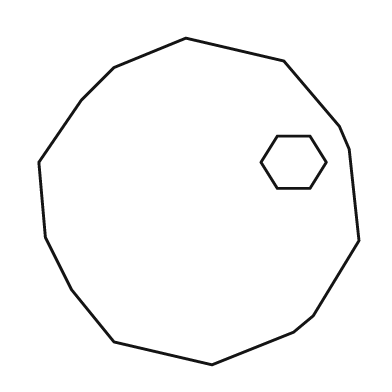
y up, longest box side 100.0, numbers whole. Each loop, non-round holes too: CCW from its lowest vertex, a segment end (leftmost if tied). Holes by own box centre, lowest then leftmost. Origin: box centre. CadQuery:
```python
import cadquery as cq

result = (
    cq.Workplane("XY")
    .moveTo(4.0, -50.0)
    .lineTo(29.0, -40.0)
    .lineTo(35.0, -35.0)
    .lineTo(49.0, -12.0)
    .lineTo(46.0, 16.0)
    .lineTo(43.0, 23.0)
    .lineTo(26.0, 43.0)
    .lineTo(-4.0, 50.0)
    .lineTo(-26.0, 41.0)
    .lineTo(-36.0, 31.0)
    .lineTo(-49.0, 12.0)
    .lineTo(-47.0, -11.0)
    .lineTo(-39.0, -27.0)
    .lineTo(-26.0, -43.0)
    .close()
    .moveTo(24.0, 4.0)
    .lineTo(34.0, 4.0)
    .lineTo(39.0, 12.0)
    .lineTo(34.0, 20.0)
    .lineTo(24.0, 20.0)
    .lineTo(19.0, 12.0)
    .close()
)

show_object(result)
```